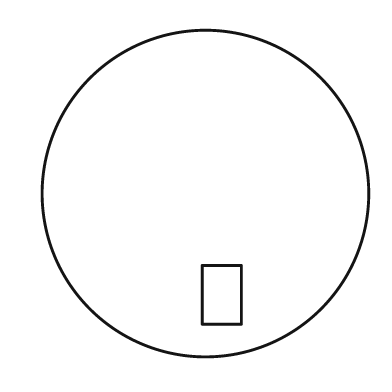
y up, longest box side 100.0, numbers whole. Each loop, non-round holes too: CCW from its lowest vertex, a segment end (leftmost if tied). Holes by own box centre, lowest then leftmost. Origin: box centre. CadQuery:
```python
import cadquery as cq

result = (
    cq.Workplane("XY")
    .moveTo(0.0, 0.0)
    .circle(50.0)
    .moveTo(-1.0, -40.0)
    .lineTo(11.0, -40.0)
    .lineTo(11.0, -22.0)
    .lineTo(-1.0, -22.0)
    .close()
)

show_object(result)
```